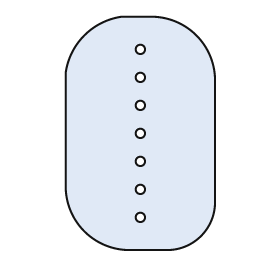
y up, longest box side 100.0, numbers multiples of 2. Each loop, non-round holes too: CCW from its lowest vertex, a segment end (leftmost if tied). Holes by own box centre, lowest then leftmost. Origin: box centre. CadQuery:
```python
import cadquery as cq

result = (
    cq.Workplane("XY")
    .moveTo(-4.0, -50.0)
    .lineTo(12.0, -50.0)
    .threePointArc((26.0, -44.0), (32.0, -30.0))
    .lineTo(32.0, 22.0)
    .threePointArc((24.0, 42.0), (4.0, 50.0))
    .lineTo(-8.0, 50.0)
    .threePointArc((-24.0, 42.0), (-32.0, 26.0))
    .lineTo(-32.0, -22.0)
    .threePointArc((-24.0, -42.0), (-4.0, -50.0))
    .close()
    .moveTo(0.0, -36.0)
    .circle(2.0)
    .moveTo(0.0, -24.0)
    .circle(2.0)
    .moveTo(0.0, -12.0)
    .circle(2.0)
    .moveTo(0.0, 0.0)
    .circle(2.0)
    .moveTo(0.0, 12.0)
    .circle(2.0)
    .moveTo(0.0, 24.0)
    .circle(2.0)
    .moveTo(0.0, 36.0)
    .circle(2.0)
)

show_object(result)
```